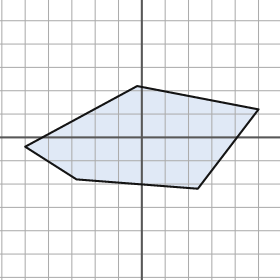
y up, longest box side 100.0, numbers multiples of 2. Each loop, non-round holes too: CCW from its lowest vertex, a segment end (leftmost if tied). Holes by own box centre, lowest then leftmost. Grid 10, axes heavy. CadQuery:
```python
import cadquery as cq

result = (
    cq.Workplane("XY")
    .moveTo(24.0, -22.0)
    .lineTo(50.0, 12.0)
    .lineTo(-2.0, 22.0)
    .lineTo(-50.0, -4.0)
    .lineTo(-28.0, -18.0)
    .close()
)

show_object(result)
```